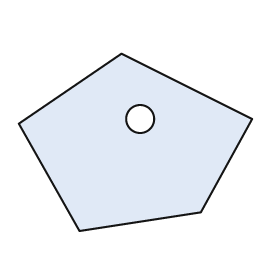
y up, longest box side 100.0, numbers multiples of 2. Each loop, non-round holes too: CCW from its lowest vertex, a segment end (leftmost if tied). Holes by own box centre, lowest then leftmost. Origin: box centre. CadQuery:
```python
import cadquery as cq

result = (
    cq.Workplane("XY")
    .moveTo(-24.0, -38.0)
    .lineTo(28.0, -30.0)
    .lineTo(50.0, 10.0)
    .lineTo(-6.0, 38.0)
    .lineTo(-50.0, 8.0)
    .close()
    .moveTo(2.0, 10.0)
    .circle(6.0)
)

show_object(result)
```